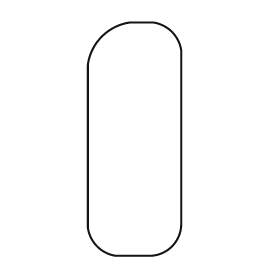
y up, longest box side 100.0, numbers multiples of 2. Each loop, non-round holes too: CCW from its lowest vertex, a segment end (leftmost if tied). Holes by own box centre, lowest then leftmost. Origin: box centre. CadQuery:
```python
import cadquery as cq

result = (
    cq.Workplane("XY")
    .moveTo(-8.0, -50.0)
    .lineTo(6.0, -50.0)
    .threePointArc((16.0, -46.0), (20.0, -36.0))
    .lineTo(20.0, 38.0)
    .threePointArc((16.0, 46.0), (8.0, 50.0))
    .lineTo(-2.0, 50.0)
    .threePointArc((-14.0, 44.0), (-20.0, 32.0))
    .lineTo(-20.0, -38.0)
    .threePointArc((-16.0, -46.0), (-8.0, -50.0))
    .close()
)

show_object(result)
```